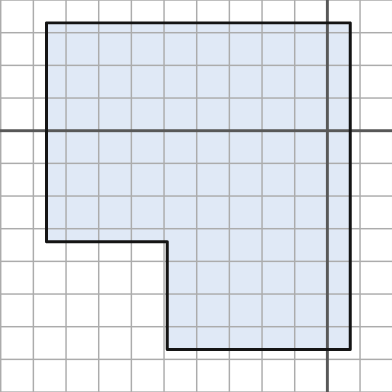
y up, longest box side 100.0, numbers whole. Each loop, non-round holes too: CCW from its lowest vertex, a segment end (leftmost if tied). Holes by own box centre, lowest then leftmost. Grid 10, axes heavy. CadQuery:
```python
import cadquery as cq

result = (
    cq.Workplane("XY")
    .moveTo(-49.0, -67.0)
    .lineTo(7.0, -67.0)
    .lineTo(7.0, 33.0)
    .lineTo(-86.0, 33.0)
    .lineTo(-86.0, -34.0)
    .lineTo(-49.0, -34.0)
    .close()
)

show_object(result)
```